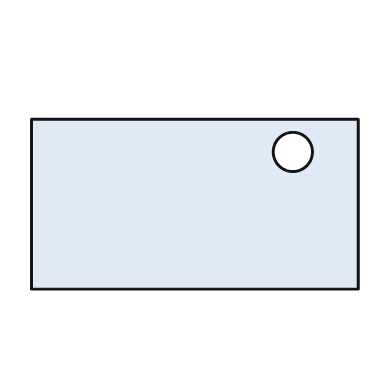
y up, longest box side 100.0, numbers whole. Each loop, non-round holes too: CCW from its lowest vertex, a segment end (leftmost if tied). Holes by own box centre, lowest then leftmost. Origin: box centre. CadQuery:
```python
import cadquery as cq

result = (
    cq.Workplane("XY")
    .moveTo(-50.0, -26.0)
    .lineTo(50.0, -26.0)
    .lineTo(50.0, 26.0)
    .lineTo(-50.0, 26.0)
    .close()
    .moveTo(30.0, 16.0)
    .circle(6.0)
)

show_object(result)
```